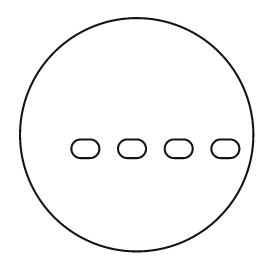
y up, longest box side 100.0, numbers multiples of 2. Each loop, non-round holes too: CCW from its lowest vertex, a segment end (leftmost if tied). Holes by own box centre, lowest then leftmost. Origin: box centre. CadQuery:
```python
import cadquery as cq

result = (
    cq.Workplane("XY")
    .moveTo(0.0, 0.0)
    .circle(50.0)
    .moveTo(-24.0, -10.0)
    .lineTo(-20.0, -10.0)
    .threePointArc((-16.0, -6.0), (-20.0, -2.0))
    .lineTo(-24.0, -2.0)
    .threePointArc((-28.0, -6.0), (-24.0, -10.0))
    .close()
    .moveTo(-4.0, -10.0)
    .lineTo(0.0, -10.0)
    .threePointArc((4.0, -6.0), (0.0, -2.0))
    .lineTo(-4.0, -2.0)
    .threePointArc((-8.0, -6.0), (-4.0, -10.0))
    .close()
    .moveTo(16.0, -10.0)
    .lineTo(20.0, -10.0)
    .threePointArc((24.0, -6.0), (20.0, -2.0))
    .lineTo(16.0, -2.0)
    .threePointArc((12.0, -6.0), (16.0, -10.0))
    .close()
    .moveTo(36.0, -10.0)
    .lineTo(40.0, -10.0)
    .threePointArc((44.0, -6.0), (40.0, -2.0))
    .lineTo(36.0, -2.0)
    .threePointArc((32.0, -6.0), (36.0, -10.0))
    .close()
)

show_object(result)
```